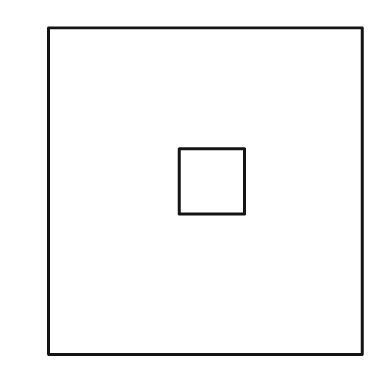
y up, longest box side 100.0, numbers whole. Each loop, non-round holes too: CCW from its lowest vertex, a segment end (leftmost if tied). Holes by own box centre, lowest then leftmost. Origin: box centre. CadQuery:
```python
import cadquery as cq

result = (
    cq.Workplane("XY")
    .moveTo(-48.0, -50.0)
    .lineTo(48.0, -50.0)
    .lineTo(48.0, 50.0)
    .lineTo(-48.0, 50.0)
    .close()
    .moveTo(-8.0, -7.0)
    .lineTo(12.0, -7.0)
    .lineTo(12.0, 13.0)
    .lineTo(-8.0, 13.0)
    .close()
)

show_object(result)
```